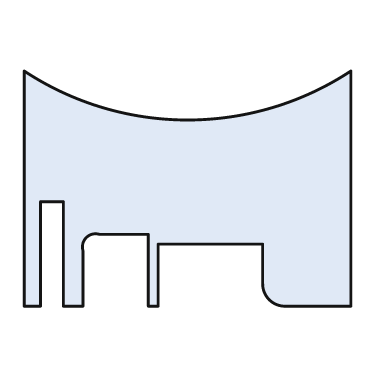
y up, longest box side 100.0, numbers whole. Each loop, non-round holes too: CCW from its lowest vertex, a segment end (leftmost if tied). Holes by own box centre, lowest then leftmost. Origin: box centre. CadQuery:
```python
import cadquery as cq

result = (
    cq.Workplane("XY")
    .moveTo(-50.0, -36.0)
    .lineTo(-45.0, -36.0)
    .lineTo(-45.0, -4.0)
    .lineTo(-38.0, -4.0)
    .lineTo(-38.0, -36.0)
    .lineTo(-32.0, -36.0)
    .lineTo(-32.0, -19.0)
    .threePointArc((-31.0, -15.0), (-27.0, -14.0))
    .lineTo(-12.0, -14.0)
    .lineTo(-12.0, -36.0)
    .lineTo(-9.0, -36.0)
    .lineTo(-9.0, -17.0)
    .lineTo(23.0, -17.0)
    .lineTo(23.0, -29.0)
    .threePointArc((25.0, -34.0), (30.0, -36.0))
    .lineTo(50.0, -36.0)
    .lineTo(50.0, 36.0)
    .threePointArc((0.0, 21.0), (-50.0, 36.0))
    .close()
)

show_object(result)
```